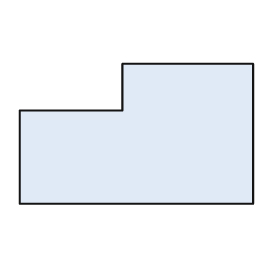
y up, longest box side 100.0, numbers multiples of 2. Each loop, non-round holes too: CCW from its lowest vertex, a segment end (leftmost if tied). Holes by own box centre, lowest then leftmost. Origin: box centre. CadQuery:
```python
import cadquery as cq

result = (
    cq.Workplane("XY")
    .moveTo(-50.0, -30.0)
    .lineTo(50.0, -30.0)
    .lineTo(50.0, 30.0)
    .lineTo(-6.0, 30.0)
    .lineTo(-6.0, 10.0)
    .lineTo(-50.0, 10.0)
    .close()
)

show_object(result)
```